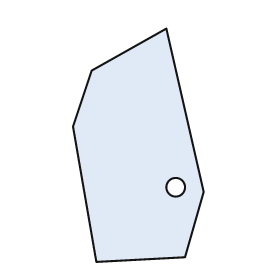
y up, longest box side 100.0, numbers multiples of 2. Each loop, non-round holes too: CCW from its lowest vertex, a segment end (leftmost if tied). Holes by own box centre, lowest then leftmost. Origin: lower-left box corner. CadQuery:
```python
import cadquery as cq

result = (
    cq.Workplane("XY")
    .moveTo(10.0, 0.0)
    .lineTo(48.0, 2.0)
    .lineTo(56.0, 30.0)
    .lineTo(40.0, 100.0)
    .lineTo(8.0, 82.0)
    .lineTo(0.0, 58.0)
    .close()
    .moveTo(44.0, 32.0)
    .circle(4.0)
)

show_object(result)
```